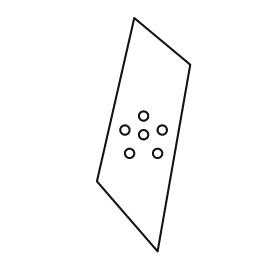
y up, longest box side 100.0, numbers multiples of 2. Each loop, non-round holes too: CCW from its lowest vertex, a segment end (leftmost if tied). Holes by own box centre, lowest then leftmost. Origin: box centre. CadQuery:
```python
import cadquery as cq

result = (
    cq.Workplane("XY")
    .moveTo(6.0, -50.0)
    .lineTo(20.0, 30.0)
    .lineTo(-4.0, 50.0)
    .lineTo(-20.0, -20.0)
    .close()
    .moveTo(-6.0, -8.0)
    .circle(2.0)
    .moveTo(6.0, -8.0)
    .circle(2.0)
    .moveTo(0.0, 0.0)
    .circle(2.0)
    .moveTo(-8.0, 2.0)
    .circle(2.0)
    .moveTo(8.0, 2.0)
    .circle(2.0)
    .moveTo(0.0, 8.0)
    .circle(2.0)
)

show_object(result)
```